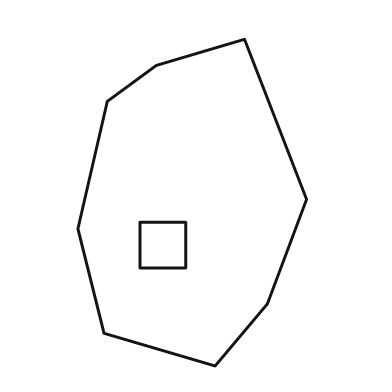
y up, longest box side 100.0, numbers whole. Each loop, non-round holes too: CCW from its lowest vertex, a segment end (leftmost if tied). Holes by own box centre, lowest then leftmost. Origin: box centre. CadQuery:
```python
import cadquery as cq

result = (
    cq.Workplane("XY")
    .moveTo(7.0, -50.0)
    .lineTo(23.0, -31.0)
    .lineTo(35.0, 1.0)
    .lineTo(16.0, 50.0)
    .lineTo(-11.0, 42.0)
    .lineTo(-26.0, 31.0)
    .lineTo(-35.0, -8.0)
    .lineTo(-27.0, -40.0)
    .close()
    .moveTo(-16.0, -20.0)
    .lineTo(-2.0, -20.0)
    .lineTo(-2.0, -6.0)
    .lineTo(-16.0, -6.0)
    .close()
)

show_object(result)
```